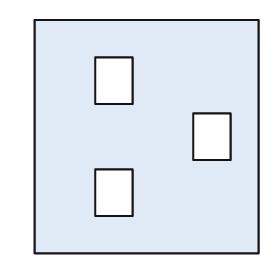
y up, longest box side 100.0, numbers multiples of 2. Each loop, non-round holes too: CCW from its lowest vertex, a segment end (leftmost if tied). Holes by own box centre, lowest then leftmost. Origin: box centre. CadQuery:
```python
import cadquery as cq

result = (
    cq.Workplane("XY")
    .moveTo(-48.0, -50.0)
    .lineTo(48.0, -50.0)
    .lineTo(48.0, 50.0)
    .lineTo(-48.0, 50.0)
    .close()
    .moveTo(-22.0, -34.0)
    .lineTo(-6.0, -34.0)
    .lineTo(-6.0, -14.0)
    .lineTo(-22.0, -14.0)
    .close()
    .moveTo(20.0, -10.0)
    .lineTo(36.0, -10.0)
    .lineTo(36.0, 10.0)
    .lineTo(20.0, 10.0)
    .close()
    .moveTo(-22.0, 14.0)
    .lineTo(-6.0, 14.0)
    .lineTo(-6.0, 34.0)
    .lineTo(-22.0, 34.0)
    .close()
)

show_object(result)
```